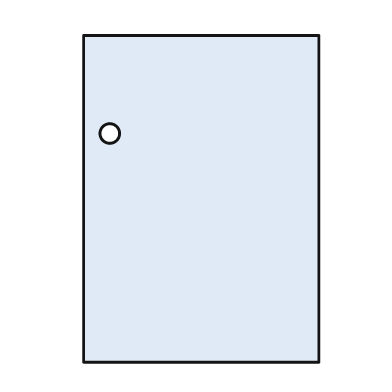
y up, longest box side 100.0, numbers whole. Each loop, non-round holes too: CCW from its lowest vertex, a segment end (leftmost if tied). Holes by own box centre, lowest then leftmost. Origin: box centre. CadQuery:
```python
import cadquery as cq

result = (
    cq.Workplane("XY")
    .moveTo(-36.0, -50.0)
    .lineTo(36.0, -50.0)
    .lineTo(36.0, 50.0)
    .lineTo(-36.0, 50.0)
    .close()
    .moveTo(-28.0, 20.0)
    .circle(3.0)
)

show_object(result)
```